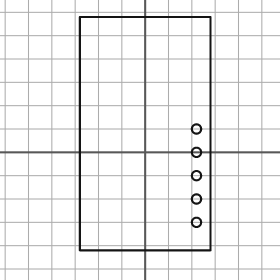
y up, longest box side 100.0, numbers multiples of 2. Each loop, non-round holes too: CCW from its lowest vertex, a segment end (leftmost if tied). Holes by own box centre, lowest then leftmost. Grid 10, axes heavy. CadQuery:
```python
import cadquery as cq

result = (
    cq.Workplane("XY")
    .moveTo(-28.0, -42.0)
    .lineTo(28.0, -42.0)
    .lineTo(28.0, 58.0)
    .lineTo(-28.0, 58.0)
    .close()
    .moveTo(22.0, -30.0)
    .circle(2.0)
    .moveTo(22.0, -20.0)
    .circle(2.0)
    .moveTo(22.0, -10.0)
    .circle(2.0)
    .moveTo(22.0, 0.0)
    .circle(2.0)
    .moveTo(22.0, 10.0)
    .circle(2.0)
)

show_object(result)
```